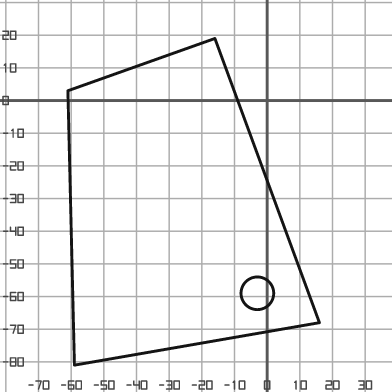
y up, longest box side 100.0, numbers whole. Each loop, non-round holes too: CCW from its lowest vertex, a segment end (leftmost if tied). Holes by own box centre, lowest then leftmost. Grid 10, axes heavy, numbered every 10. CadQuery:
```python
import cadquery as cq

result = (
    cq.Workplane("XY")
    .moveTo(-59.0, -81.0)
    .lineTo(16.0, -68.0)
    .lineTo(-16.0, 19.0)
    .lineTo(-61.0, 3.0)
    .close()
    .moveTo(-3.0, -59.0)
    .circle(5.0)
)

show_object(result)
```